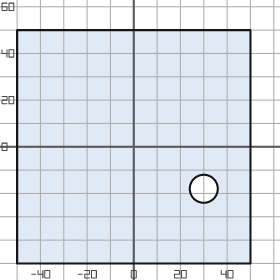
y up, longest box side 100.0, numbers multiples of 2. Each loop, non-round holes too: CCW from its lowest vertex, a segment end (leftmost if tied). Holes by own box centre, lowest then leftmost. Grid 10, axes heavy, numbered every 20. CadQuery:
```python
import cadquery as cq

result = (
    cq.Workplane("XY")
    .moveTo(-50.0, -50.0)
    .lineTo(50.0, -50.0)
    .lineTo(50.0, 50.0)
    .lineTo(-50.0, 50.0)
    .close()
    .moveTo(30.0, -18.0)
    .circle(6.0)
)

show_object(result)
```